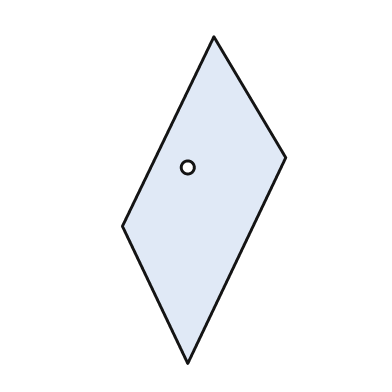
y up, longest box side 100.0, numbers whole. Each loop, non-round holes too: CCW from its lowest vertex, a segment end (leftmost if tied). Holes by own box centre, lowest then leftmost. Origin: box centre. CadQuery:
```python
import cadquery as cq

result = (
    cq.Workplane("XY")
    .moveTo(-5.0, -50.0)
    .lineTo(25.0, 13.0)
    .lineTo(3.0, 50.0)
    .lineTo(-25.0, -8.0)
    .close()
    .moveTo(-5.0, 10.0)
    .circle(2.0)
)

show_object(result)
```